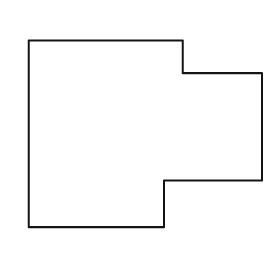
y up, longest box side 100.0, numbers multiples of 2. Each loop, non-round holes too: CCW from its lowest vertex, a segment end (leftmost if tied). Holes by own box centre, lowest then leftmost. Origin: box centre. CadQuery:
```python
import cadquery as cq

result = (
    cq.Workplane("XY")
    .moveTo(-50.0, -40.0)
    .lineTo(8.0, -40.0)
    .lineTo(8.0, -20.0)
    .lineTo(50.0, -20.0)
    .lineTo(50.0, 26.0)
    .lineTo(16.0, 26.0)
    .lineTo(16.0, 40.0)
    .lineTo(-50.0, 40.0)
    .close()
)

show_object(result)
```